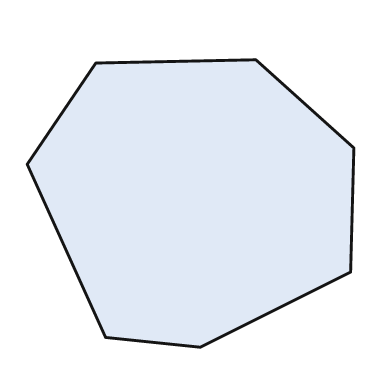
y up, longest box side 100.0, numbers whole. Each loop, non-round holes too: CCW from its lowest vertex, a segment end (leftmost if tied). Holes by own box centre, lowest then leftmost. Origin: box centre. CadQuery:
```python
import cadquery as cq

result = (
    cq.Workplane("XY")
    .moveTo(3.0, -44.0)
    .lineTo(49.0, -21.0)
    .lineTo(50.0, 17.0)
    .lineTo(20.0, 44.0)
    .lineTo(-29.0, 43.0)
    .lineTo(-50.0, 12.0)
    .lineTo(-26.0, -41.0)
    .close()
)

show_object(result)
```